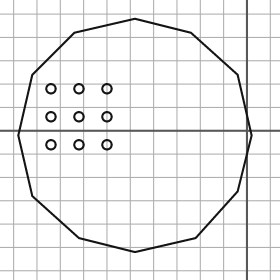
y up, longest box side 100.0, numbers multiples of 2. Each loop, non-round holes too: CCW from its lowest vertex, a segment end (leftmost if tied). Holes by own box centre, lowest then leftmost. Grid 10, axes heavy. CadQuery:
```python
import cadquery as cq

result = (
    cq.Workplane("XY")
    .moveTo(-48.0, -52.0)
    .lineTo(-22.0, -46.0)
    .lineTo(-4.0, -26.0)
    .lineTo(2.0, -2.0)
    .lineTo(-4.0, 24.0)
    .lineTo(-24.0, 42.0)
    .lineTo(-48.0, 48.0)
    .lineTo(-74.0, 42.0)
    .lineTo(-92.0, 24.0)
    .lineTo(-98.0, -2.0)
    .lineTo(-92.0, -28.0)
    .lineTo(-72.0, -46.0)
    .close()
    .moveTo(-84.0, -6.0)
    .circle(2.0)
    .moveTo(-72.0, -6.0)
    .circle(2.0)
    .moveTo(-60.0, -6.0)
    .circle(2.0)
    .moveTo(-84.0, 6.0)
    .circle(2.0)
    .moveTo(-72.0, 6.0)
    .circle(2.0)
    .moveTo(-60.0, 6.0)
    .circle(2.0)
    .moveTo(-84.0, 18.0)
    .circle(2.0)
    .moveTo(-72.0, 18.0)
    .circle(2.0)
    .moveTo(-60.0, 18.0)
    .circle(2.0)
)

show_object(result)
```